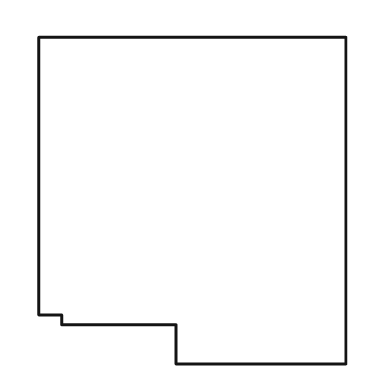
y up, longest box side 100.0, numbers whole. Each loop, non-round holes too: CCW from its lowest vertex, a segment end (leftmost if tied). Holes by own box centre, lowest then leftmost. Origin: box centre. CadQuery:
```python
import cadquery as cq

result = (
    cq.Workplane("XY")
    .moveTo(-5.0, -50.0)
    .lineTo(47.0, -50.0)
    .lineTo(47.0, 50.0)
    .lineTo(-47.0, 50.0)
    .lineTo(-47.0, -35.0)
    .lineTo(-40.0, -35.0)
    .lineTo(-40.0, -38.0)
    .lineTo(-5.0, -38.0)
    .close()
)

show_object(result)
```